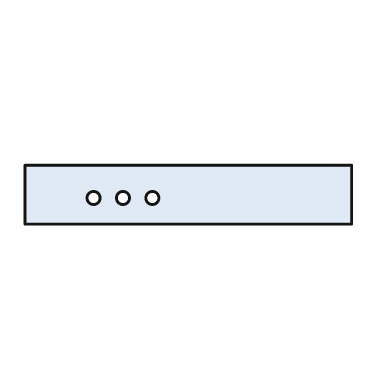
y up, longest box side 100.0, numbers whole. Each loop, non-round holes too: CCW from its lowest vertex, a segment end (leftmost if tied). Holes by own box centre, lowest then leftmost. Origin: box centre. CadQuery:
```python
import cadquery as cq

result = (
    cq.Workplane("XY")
    .moveTo(-50.0, -9.0)
    .lineTo(50.0, -9.0)
    .lineTo(50.0, 9.0)
    .lineTo(-50.0, 9.0)
    .close()
    .moveTo(-29.0, -1.0)
    .circle(2.0)
    .moveTo(-20.0, -1.0)
    .circle(2.0)
    .moveTo(-11.0, -1.0)
    .circle(2.0)
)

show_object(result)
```